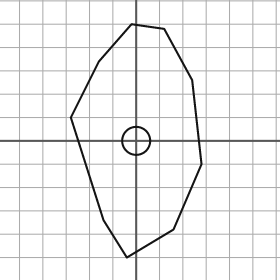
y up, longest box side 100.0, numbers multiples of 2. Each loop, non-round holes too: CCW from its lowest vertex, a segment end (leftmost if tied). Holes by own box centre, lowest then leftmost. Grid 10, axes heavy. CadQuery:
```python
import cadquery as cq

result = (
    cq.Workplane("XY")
    .moveTo(-4.0, -50.0)
    .lineTo(16.0, -38.0)
    .lineTo(28.0, -10.0)
    .lineTo(24.0, 26.0)
    .lineTo(12.0, 48.0)
    .lineTo(-2.0, 50.0)
    .lineTo(-16.0, 34.0)
    .lineTo(-28.0, 10.0)
    .lineTo(-14.0, -34.0)
    .close()
    .moveTo(0.0, 0.0)
    .circle(6.0)
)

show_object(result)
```